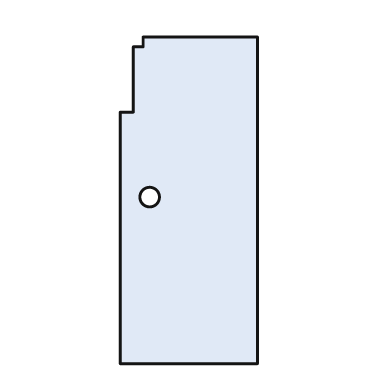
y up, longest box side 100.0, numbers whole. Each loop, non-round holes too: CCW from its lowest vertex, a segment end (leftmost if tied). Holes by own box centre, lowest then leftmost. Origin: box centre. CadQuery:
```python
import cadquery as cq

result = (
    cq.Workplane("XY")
    .moveTo(-21.0, -50.0)
    .lineTo(21.0, -50.0)
    .lineTo(21.0, 50.0)
    .lineTo(-14.0, 50.0)
    .lineTo(-14.0, 47.0)
    .lineTo(-17.0, 47.0)
    .lineTo(-17.0, 27.0)
    .lineTo(-21.0, 27.0)
    .close()
    .moveTo(-12.0, 1.0)
    .circle(3.0)
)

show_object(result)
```